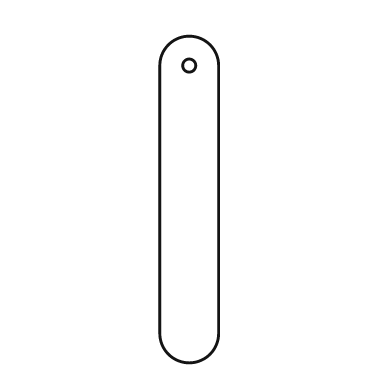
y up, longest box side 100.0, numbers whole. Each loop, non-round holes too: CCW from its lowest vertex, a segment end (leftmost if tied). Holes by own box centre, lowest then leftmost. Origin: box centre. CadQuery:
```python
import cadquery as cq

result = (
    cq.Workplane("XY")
    .moveTo(-9.0, -41.0)
    .threePointArc((0.0, -50.0), (9.0, -41.0))
    .lineTo(9.0, 41.0)
    .threePointArc((0.0, 50.0), (-9.0, 41.0))
    .close()
    .moveTo(0.0, 41.0)
    .circle(2.0)
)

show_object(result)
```